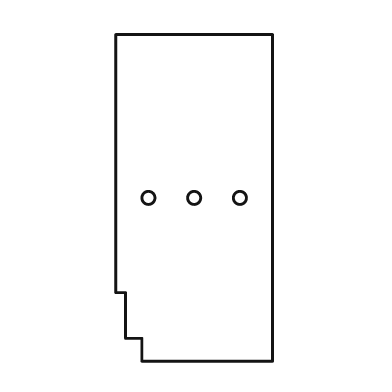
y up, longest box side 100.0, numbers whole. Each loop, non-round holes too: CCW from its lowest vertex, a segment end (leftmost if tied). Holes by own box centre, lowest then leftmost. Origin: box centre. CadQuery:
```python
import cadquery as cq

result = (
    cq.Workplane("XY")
    .moveTo(-16.0, -50.0)
    .lineTo(24.0, -50.0)
    .lineTo(24.0, 50.0)
    .lineTo(-24.0, 50.0)
    .lineTo(-24.0, -29.0)
    .lineTo(-21.0, -29.0)
    .lineTo(-21.0, -43.0)
    .lineTo(-16.0, -43.0)
    .close()
    .moveTo(-14.0, 0.0)
    .circle(2.0)
    .moveTo(0.0, 0.0)
    .circle(2.0)
    .moveTo(14.0, 0.0)
    .circle(2.0)
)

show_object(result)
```